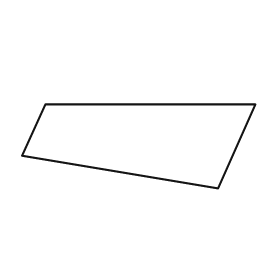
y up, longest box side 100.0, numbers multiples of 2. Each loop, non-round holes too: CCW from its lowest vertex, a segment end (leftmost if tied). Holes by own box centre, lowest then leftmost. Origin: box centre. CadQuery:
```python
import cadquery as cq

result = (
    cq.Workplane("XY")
    .moveTo(34.0, -18.0)
    .lineTo(50.0, 18.0)
    .lineTo(-40.0, 18.0)
    .lineTo(-50.0, -4.0)
    .close()
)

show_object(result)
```